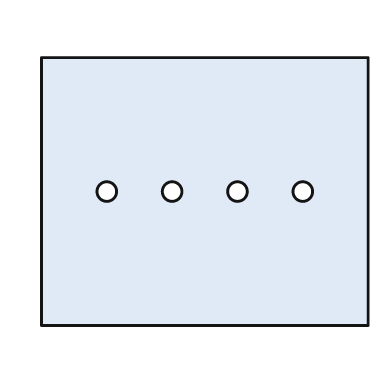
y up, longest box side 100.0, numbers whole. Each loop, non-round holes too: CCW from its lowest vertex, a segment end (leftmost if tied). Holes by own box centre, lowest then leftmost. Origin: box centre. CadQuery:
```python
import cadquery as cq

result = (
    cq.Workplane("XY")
    .moveTo(-50.0, -41.0)
    .lineTo(50.0, -41.0)
    .lineTo(50.0, 41.0)
    .lineTo(-50.0, 41.0)
    .close()
    .moveTo(-30.0, 0.0)
    .circle(3.0)
    .moveTo(-10.0, 0.0)
    .circle(3.0)
    .moveTo(10.0, 0.0)
    .circle(3.0)
    .moveTo(30.0, 0.0)
    .circle(3.0)
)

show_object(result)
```